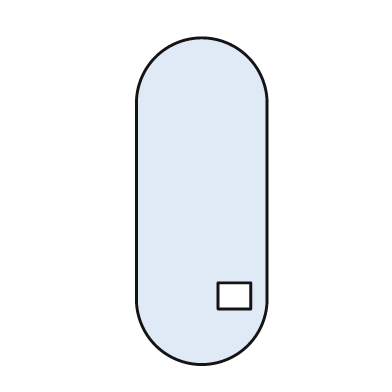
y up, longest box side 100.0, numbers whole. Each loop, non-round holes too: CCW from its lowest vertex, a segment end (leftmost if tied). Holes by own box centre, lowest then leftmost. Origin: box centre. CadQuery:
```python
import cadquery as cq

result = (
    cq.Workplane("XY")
    .moveTo(-20.0, -30.0)
    .threePointArc((0.0, -50.0), (20.0, -30.0))
    .lineTo(20.0, 30.0)
    .threePointArc((0.0, 50.0), (-20.0, 30.0))
    .close()
    .moveTo(5.0, -33.0)
    .lineTo(15.0, -33.0)
    .lineTo(15.0, -25.0)
    .lineTo(5.0, -25.0)
    .close()
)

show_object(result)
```